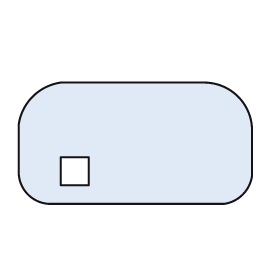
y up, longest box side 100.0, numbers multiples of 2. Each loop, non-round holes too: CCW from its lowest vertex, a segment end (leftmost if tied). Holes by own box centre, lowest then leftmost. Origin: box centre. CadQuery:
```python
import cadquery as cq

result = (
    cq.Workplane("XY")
    .moveTo(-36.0, -26.0)
    .lineTo(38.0, -26.0)
    .threePointArc((46.0, -22.0), (50.0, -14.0))
    .lineTo(50.0, 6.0)
    .threePointArc((44.0, 20.0), (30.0, 26.0))
    .lineTo(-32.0, 26.0)
    .threePointArc((-44.0, 20.0), (-50.0, 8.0))
    .lineTo(-50.0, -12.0)
    .threePointArc((-46.0, -22.0), (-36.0, -26.0))
    .close()
    .moveTo(-32.0, -18.0)
    .lineTo(-20.0, -18.0)
    .lineTo(-20.0, -6.0)
    .lineTo(-32.0, -6.0)
    .close()
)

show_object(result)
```